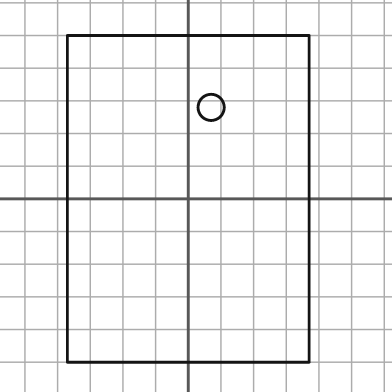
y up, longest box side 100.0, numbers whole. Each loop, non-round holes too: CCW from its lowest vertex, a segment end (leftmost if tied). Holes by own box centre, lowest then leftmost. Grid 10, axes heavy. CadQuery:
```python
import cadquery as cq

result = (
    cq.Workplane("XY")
    .moveTo(-37.0, -50.0)
    .lineTo(37.0, -50.0)
    .lineTo(37.0, 50.0)
    .lineTo(-37.0, 50.0)
    .close()
    .moveTo(7.0, 28.0)
    .circle(4.0)
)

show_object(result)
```